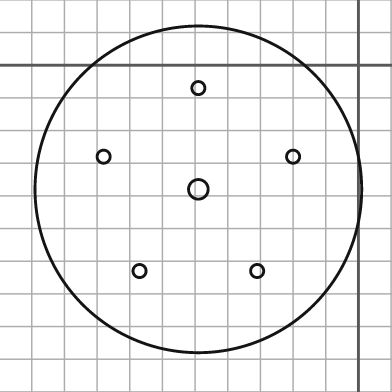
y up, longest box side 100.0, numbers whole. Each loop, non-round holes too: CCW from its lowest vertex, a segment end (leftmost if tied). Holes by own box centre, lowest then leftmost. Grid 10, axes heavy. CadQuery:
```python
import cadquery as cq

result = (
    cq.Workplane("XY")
    .moveTo(-49.0, -38.0)
    .circle(50.0)
    .moveTo(-67.0, -63.0)
    .circle(2.0)
    .moveTo(-31.0, -63.0)
    .circle(2.0)
    .moveTo(-49.0, -38.0)
    .circle(3.0)
    .moveTo(-78.0, -28.0)
    .circle(2.0)
    .moveTo(-20.0, -28.0)
    .circle(2.0)
    .moveTo(-49.0, -7.0)
    .circle(2.0)
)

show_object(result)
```